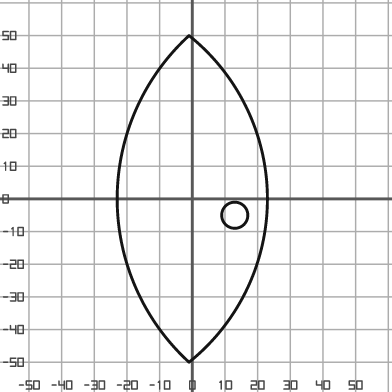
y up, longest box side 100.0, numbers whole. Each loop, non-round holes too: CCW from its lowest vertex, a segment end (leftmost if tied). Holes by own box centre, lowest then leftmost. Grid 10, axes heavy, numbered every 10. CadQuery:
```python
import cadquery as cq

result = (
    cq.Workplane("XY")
    .moveTo(-1.0, -50.0)
    .threePointArc((23.0, 0.0), (-1.0, 50.0))
    .threePointArc((-23.0, 0.0), (-1.0, -50.0))
    .close()
    .moveTo(13.0, -5.0)
    .circle(4.0)
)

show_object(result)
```